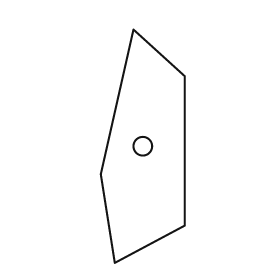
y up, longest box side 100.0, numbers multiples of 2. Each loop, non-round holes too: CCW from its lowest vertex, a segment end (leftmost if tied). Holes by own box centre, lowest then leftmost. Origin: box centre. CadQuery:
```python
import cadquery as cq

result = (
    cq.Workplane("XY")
    .moveTo(-12.0, -50.0)
    .lineTo(18.0, -34.0)
    .lineTo(18.0, 30.0)
    .lineTo(-4.0, 50.0)
    .lineTo(-18.0, -12.0)
    .close()
    .moveTo(0.0, 0.0)
    .circle(4.0)
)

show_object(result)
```